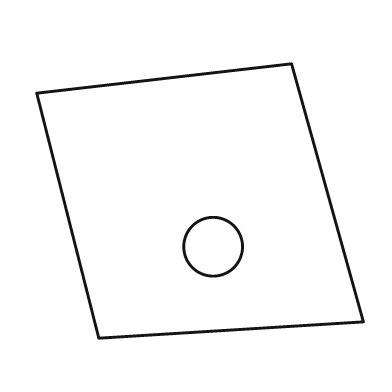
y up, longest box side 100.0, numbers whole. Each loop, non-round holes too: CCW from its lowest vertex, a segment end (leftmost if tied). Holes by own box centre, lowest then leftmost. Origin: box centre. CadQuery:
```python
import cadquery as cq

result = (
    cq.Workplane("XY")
    .moveTo(-31.0, -42.0)
    .lineTo(50.0, -37.0)
    .lineTo(28.0, 42.0)
    .lineTo(-50.0, 33.0)
    .close()
    .moveTo(4.0, -14.0)
    .circle(9.0)
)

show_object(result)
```